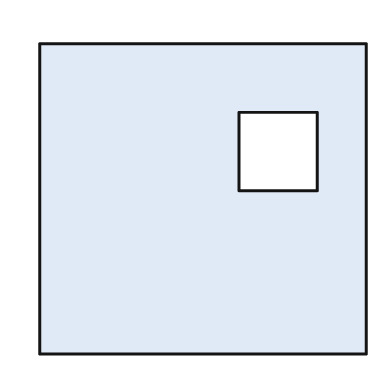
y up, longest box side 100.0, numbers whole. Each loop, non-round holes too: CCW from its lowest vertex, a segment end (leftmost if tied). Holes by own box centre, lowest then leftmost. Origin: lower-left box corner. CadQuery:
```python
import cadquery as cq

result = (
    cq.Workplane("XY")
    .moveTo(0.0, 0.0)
    .lineTo(100.0, 0.0)
    .lineTo(100.0, 95.0)
    .lineTo(0.0, 95.0)
    .close()
    .moveTo(61.0, 50.0)
    .lineTo(85.0, 50.0)
    .lineTo(85.0, 74.0)
    .lineTo(61.0, 74.0)
    .close()
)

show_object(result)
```